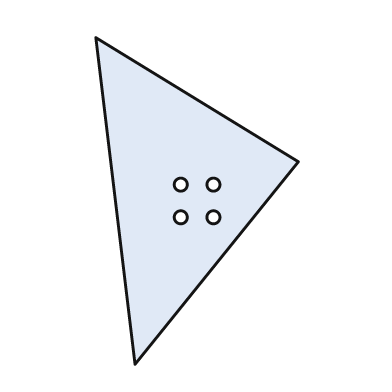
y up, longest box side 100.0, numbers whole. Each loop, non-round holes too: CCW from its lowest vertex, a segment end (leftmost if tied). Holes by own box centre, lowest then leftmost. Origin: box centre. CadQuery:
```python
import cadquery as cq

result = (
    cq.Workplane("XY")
    .moveTo(-19.0, -50.0)
    .lineTo(31.0, 12.0)
    .lineTo(-31.0, 50.0)
    .close()
    .moveTo(-5.0, -5.0)
    .circle(2.0)
    .moveTo(5.0, -5.0)
    .circle(2.0)
    .moveTo(-5.0, 5.0)
    .circle(2.0)
    .moveTo(5.0, 5.0)
    .circle(2.0)
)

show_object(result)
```